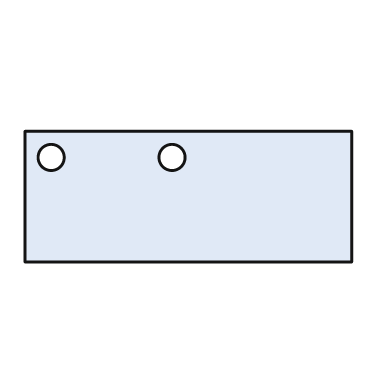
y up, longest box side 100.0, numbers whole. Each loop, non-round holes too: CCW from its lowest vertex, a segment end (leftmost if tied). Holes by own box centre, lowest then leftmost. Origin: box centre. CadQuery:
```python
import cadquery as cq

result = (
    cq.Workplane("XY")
    .moveTo(-50.0, -20.0)
    .lineTo(50.0, -20.0)
    .lineTo(50.0, 20.0)
    .lineTo(-50.0, 20.0)
    .close()
    .moveTo(-42.0, 12.0)
    .circle(4.0)
    .moveTo(-5.0, 12.0)
    .circle(4.0)
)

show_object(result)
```